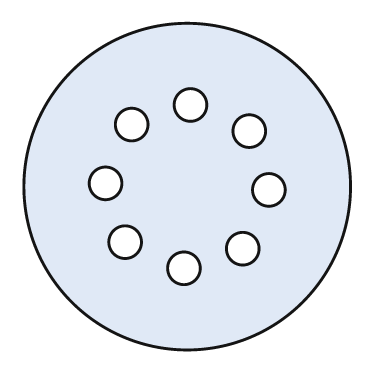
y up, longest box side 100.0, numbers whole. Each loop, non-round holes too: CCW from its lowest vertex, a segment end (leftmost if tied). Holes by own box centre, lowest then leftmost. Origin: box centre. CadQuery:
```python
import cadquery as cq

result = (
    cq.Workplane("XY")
    .moveTo(0.0, 0.0)
    .circle(50.0)
    .moveTo(-1.0, -25.0)
    .circle(5.0)
    .moveTo(17.0, -19.0)
    .circle(5.0)
    .moveTo(-19.0, -17.0)
    .circle(5.0)
    .moveTo(25.0, -1.0)
    .circle(5.0)
    .moveTo(-25.0, 1.0)
    .circle(5.0)
    .moveTo(19.0, 17.0)
    .circle(5.0)
    .moveTo(-17.0, 19.0)
    .circle(5.0)
    .moveTo(1.0, 25.0)
    .circle(5.0)
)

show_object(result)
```